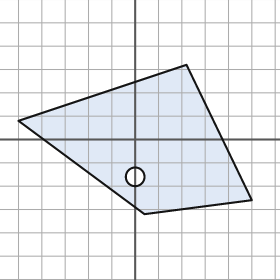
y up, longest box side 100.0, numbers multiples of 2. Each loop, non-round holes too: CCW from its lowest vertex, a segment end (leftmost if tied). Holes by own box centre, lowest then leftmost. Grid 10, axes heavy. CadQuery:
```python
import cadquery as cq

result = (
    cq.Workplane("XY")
    .moveTo(4.0, -32.0)
    .lineTo(50.0, -26.0)
    .lineTo(22.0, 32.0)
    .lineTo(-50.0, 8.0)
    .close()
    .moveTo(0.0, -16.0)
    .circle(4.0)
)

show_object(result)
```